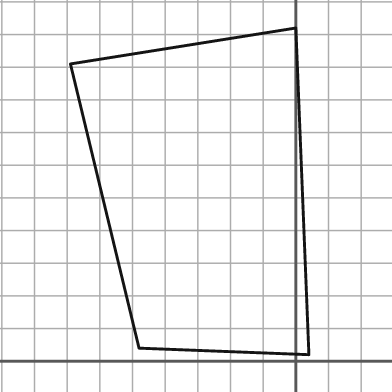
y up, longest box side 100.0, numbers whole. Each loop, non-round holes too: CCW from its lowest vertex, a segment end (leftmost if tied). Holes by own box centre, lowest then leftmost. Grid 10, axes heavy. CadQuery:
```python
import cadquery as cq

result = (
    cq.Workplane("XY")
    .moveTo(4.0, 2.0)
    .lineTo(0.0, 102.0)
    .lineTo(-69.0, 91.0)
    .lineTo(-48.0, 4.0)
    .close()
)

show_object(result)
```